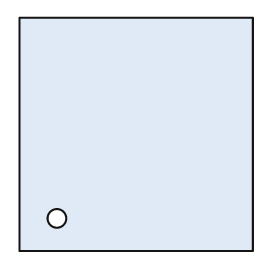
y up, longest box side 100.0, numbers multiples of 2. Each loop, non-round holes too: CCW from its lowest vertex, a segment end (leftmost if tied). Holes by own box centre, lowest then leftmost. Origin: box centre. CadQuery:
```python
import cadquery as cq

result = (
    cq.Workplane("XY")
    .moveTo(-50.0, -50.0)
    .lineTo(50.0, -50.0)
    .lineTo(50.0, 50.0)
    .lineTo(-50.0, 50.0)
    .close()
    .moveTo(-34.0, -36.0)
    .circle(4.0)
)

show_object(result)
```